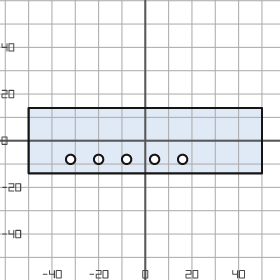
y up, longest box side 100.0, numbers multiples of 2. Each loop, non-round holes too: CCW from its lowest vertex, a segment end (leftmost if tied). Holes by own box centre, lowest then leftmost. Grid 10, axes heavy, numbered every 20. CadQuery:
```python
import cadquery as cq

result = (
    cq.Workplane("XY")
    .moveTo(-50.0, -14.0)
    .lineTo(50.0, -14.0)
    .lineTo(50.0, 14.0)
    .lineTo(-50.0, 14.0)
    .close()
    .moveTo(-32.0, -8.0)
    .circle(2.0)
    .moveTo(-20.0, -8.0)
    .circle(2.0)
    .moveTo(-8.0, -8.0)
    .circle(2.0)
    .moveTo(4.0, -8.0)
    .circle(2.0)
    .moveTo(16.0, -8.0)
    .circle(2.0)
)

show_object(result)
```